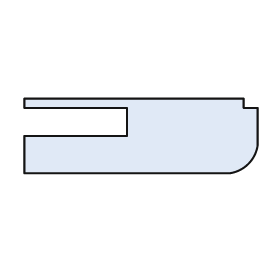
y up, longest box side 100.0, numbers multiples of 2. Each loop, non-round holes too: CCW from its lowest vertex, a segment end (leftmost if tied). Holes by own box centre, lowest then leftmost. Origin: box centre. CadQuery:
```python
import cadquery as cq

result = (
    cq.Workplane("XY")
    .moveTo(-50.0, -16.0)
    .lineTo(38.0, -16.0)
    .threePointArc((46.0, -12.0), (50.0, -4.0))
    .lineTo(50.0, 12.0)
    .lineTo(44.0, 12.0)
    .lineTo(44.0, 16.0)
    .lineTo(-50.0, 16.0)
    .lineTo(-50.0, 12.0)
    .lineTo(-6.0, 12.0)
    .lineTo(-6.0, 0.0)
    .lineTo(-50.0, 0.0)
    .close()
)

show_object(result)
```